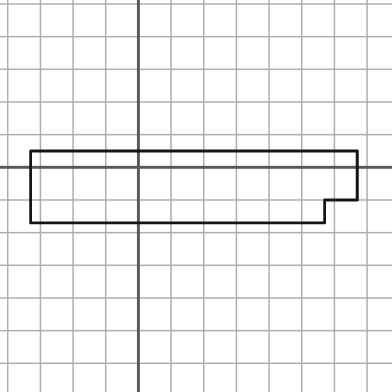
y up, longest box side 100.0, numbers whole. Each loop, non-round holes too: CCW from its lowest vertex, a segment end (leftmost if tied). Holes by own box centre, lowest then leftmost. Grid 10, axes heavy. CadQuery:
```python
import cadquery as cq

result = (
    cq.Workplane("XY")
    .moveTo(-33.0, -17.0)
    .lineTo(57.0, -17.0)
    .lineTo(57.0, -10.0)
    .lineTo(67.0, -10.0)
    .lineTo(67.0, 5.0)
    .lineTo(-33.0, 5.0)
    .close()
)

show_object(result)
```